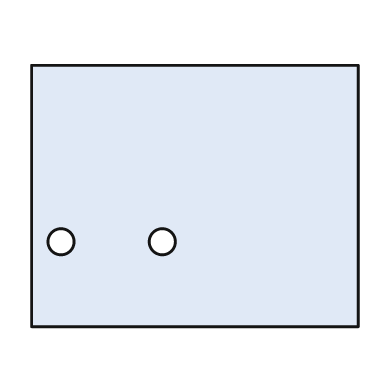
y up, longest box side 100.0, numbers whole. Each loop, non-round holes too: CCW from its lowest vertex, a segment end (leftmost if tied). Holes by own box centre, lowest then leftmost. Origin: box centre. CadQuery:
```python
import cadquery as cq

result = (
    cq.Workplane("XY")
    .moveTo(-50.0, -40.0)
    .lineTo(50.0, -40.0)
    .lineTo(50.0, 40.0)
    .lineTo(-50.0, 40.0)
    .close()
    .moveTo(-41.0, -14.0)
    .circle(4.0)
    .moveTo(-10.0, -14.0)
    .circle(4.0)
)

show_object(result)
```